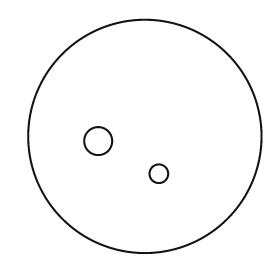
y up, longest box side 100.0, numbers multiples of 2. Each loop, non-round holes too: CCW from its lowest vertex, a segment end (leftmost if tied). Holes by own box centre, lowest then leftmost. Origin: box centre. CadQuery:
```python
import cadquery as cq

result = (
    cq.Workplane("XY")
    .moveTo(0.0, 0.0)
    .circle(50.0)
    .moveTo(6.0, -16.0)
    .circle(4.0)
    .moveTo(-20.0, -2.0)
    .circle(6.0)
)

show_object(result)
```